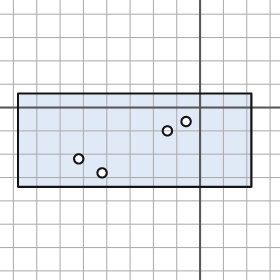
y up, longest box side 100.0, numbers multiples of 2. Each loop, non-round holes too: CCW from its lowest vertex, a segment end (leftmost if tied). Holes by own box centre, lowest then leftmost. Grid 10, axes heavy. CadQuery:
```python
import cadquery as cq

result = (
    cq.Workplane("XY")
    .moveTo(-78.0, -34.0)
    .lineTo(22.0, -34.0)
    .lineTo(22.0, 6.0)
    .lineTo(-78.0, 6.0)
    .close()
    .moveTo(-42.0, -28.0)
    .circle(2.0)
    .moveTo(-52.0, -22.0)
    .circle(2.0)
    .moveTo(-14.0, -10.0)
    .circle(2.0)
    .moveTo(-6.0, -6.0)
    .circle(2.0)
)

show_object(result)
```